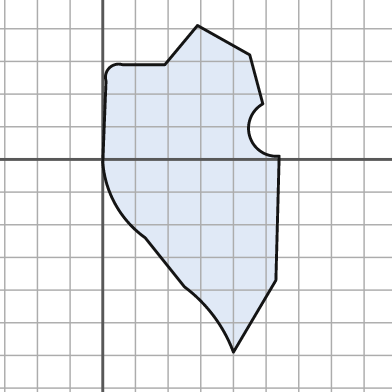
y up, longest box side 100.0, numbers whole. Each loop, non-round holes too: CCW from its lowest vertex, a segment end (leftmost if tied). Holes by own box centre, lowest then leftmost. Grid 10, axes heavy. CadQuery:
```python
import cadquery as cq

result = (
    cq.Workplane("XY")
    .moveTo(40.0, -59.0)
    .lineTo(53.0, -37.0)
    .lineTo(54.0, 1.0)
    .threePointArc((45.0, 7.0), (49.0, 17.0))
    .lineTo(45.0, 32.0)
    .lineTo(29.0, 41.0)
    .lineTo(19.0, 29.0)
    .lineTo(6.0, 29.0)
    .threePointArc((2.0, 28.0), (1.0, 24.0))
    .lineTo(0.0, -1.0)
    .threePointArc((4.0, -14.0), (13.0, -24.0))
    .lineTo(25.0, -39.0)
    .threePointArc((34.0, -48.0), (40.0, -59.0))
    .close()
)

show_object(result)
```